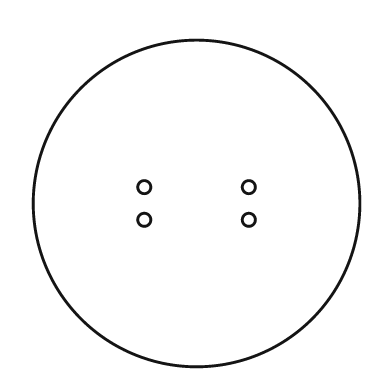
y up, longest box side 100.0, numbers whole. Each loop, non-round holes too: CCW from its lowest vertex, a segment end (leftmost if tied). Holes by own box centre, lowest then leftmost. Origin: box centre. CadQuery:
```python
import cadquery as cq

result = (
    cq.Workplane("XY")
    .moveTo(0.0, 0.0)
    .circle(50.0)
    .moveTo(-16.0, -5.0)
    .circle(2.0)
    .moveTo(16.0, -5.0)
    .circle(2.0)
    .moveTo(-16.0, 5.0)
    .circle(2.0)
    .moveTo(16.0, 5.0)
    .circle(2.0)
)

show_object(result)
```